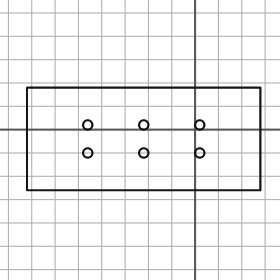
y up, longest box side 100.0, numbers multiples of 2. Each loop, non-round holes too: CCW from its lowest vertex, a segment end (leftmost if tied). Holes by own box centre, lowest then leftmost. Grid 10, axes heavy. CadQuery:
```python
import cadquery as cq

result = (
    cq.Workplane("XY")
    .moveTo(-72.0, -26.0)
    .lineTo(28.0, -26.0)
    .lineTo(28.0, 18.0)
    .lineTo(-72.0, 18.0)
    .close()
    .moveTo(-46.0, -10.0)
    .circle(2.0)
    .moveTo(-22.0, -10.0)
    .circle(2.0)
    .moveTo(2.0, -10.0)
    .circle(2.0)
    .moveTo(-46.0, 2.0)
    .circle(2.0)
    .moveTo(-22.0, 2.0)
    .circle(2.0)
    .moveTo(2.0, 2.0)
    .circle(2.0)
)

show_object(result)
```